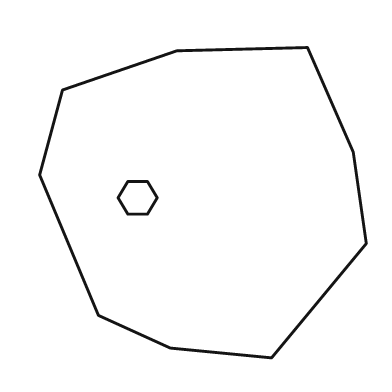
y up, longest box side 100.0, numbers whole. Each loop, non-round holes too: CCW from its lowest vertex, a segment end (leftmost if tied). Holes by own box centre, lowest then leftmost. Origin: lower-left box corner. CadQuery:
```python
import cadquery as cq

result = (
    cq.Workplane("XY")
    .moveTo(71.0, 0.0)
    .lineTo(100.0, 35.0)
    .lineTo(96.0, 63.0)
    .lineTo(82.0, 95.0)
    .lineTo(42.0, 94.0)
    .lineTo(7.0, 82.0)
    .lineTo(0.0, 56.0)
    .lineTo(18.0, 13.0)
    .lineTo(40.0, 3.0)
    .close()
    .moveTo(27.0, 44.0)
    .lineTo(33.0, 44.0)
    .lineTo(36.0, 49.0)
    .lineTo(33.0, 54.0)
    .lineTo(27.0, 54.0)
    .lineTo(24.0, 49.0)
    .close()
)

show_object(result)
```